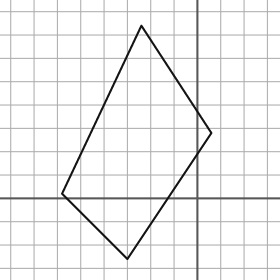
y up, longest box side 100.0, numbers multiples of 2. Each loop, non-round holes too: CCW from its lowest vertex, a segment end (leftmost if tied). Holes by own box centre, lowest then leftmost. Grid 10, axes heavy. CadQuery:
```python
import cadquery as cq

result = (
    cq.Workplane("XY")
    .moveTo(-30.0, -26.0)
    .lineTo(6.0, 28.0)
    .lineTo(-24.0, 74.0)
    .lineTo(-58.0, 2.0)
    .close()
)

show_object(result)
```